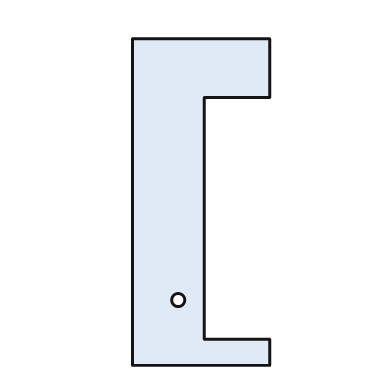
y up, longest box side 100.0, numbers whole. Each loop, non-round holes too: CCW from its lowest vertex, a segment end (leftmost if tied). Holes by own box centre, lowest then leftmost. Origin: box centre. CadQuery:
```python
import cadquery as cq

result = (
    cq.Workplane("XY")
    .moveTo(-21.0, -50.0)
    .lineTo(21.0, -50.0)
    .lineTo(21.0, -42.0)
    .lineTo(1.0, -42.0)
    .lineTo(1.0, 32.0)
    .lineTo(21.0, 32.0)
    .lineTo(21.0, 50.0)
    .lineTo(-21.0, 50.0)
    .close()
    .moveTo(-7.0, -30.0)
    .circle(2.0)
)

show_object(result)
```